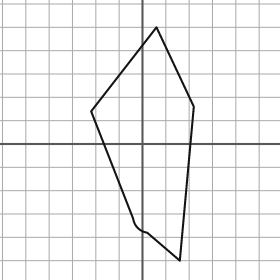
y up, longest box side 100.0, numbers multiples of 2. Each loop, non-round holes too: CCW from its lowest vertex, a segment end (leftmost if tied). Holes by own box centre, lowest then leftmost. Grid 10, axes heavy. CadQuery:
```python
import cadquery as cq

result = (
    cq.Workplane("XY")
    .moveTo(16.0, -50.0)
    .lineTo(22.0, 16.0)
    .lineTo(6.0, 50.0)
    .lineTo(-22.0, 14.0)
    .lineTo(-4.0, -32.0)
    .threePointArc((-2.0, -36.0), (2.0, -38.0))
    .close()
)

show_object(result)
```